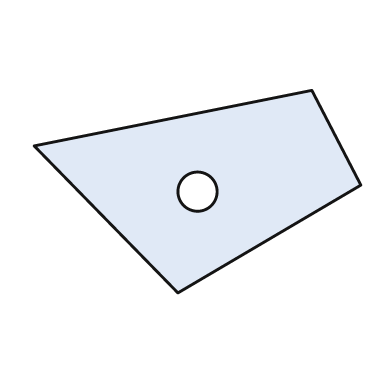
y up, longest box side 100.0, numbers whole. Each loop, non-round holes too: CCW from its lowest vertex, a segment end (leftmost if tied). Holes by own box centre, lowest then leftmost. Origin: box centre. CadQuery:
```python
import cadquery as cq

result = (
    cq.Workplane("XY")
    .moveTo(-6.0, -31.0)
    .lineTo(50.0, 2.0)
    .lineTo(35.0, 31.0)
    .lineTo(-50.0, 14.0)
    .close()
    .moveTo(0.0, 0.0)
    .circle(6.0)
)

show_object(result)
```